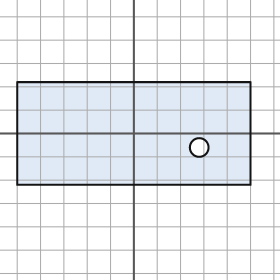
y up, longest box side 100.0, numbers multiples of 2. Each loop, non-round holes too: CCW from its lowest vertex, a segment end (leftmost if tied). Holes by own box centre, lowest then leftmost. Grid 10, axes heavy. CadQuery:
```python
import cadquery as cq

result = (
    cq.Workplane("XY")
    .moveTo(-50.0, -22.0)
    .lineTo(50.0, -22.0)
    .lineTo(50.0, 22.0)
    .lineTo(-50.0, 22.0)
    .close()
    .moveTo(28.0, -6.0)
    .circle(4.0)
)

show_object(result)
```